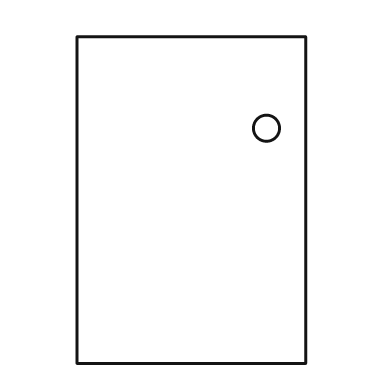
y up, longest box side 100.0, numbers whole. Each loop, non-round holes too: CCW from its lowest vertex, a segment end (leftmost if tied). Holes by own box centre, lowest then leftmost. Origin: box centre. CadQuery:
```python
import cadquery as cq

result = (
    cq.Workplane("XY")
    .moveTo(-35.0, -50.0)
    .lineTo(35.0, -50.0)
    .lineTo(35.0, 50.0)
    .lineTo(-35.0, 50.0)
    .close()
    .moveTo(23.0, 22.0)
    .circle(4.0)
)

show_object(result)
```